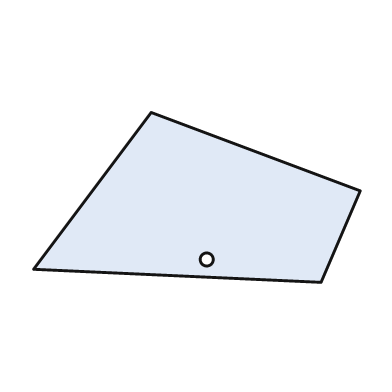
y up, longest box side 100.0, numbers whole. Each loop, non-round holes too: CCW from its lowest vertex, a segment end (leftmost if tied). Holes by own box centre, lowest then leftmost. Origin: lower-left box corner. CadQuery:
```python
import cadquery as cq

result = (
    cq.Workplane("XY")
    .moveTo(88.0, 0.0)
    .lineTo(100.0, 28.0)
    .lineTo(36.0, 52.0)
    .lineTo(0.0, 4.0)
    .close()
    .moveTo(53.0, 7.0)
    .circle(2.0)
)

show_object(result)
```